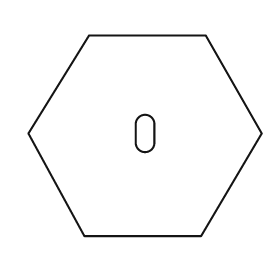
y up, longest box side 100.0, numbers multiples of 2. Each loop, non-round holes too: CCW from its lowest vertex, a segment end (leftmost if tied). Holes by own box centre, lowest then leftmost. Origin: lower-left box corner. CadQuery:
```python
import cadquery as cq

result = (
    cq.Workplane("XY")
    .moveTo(24.0, 0.0)
    .lineTo(74.0, 0.0)
    .lineTo(100.0, 44.0)
    .lineTo(76.0, 86.0)
    .lineTo(26.0, 86.0)
    .lineTo(0.0, 44.0)
    .close()
    .moveTo(46.0, 40.0)
    .threePointArc((50.0, 36.0), (54.0, 40.0))
    .lineTo(54.0, 48.0)
    .threePointArc((50.0, 52.0), (46.0, 48.0))
    .close()
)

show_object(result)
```